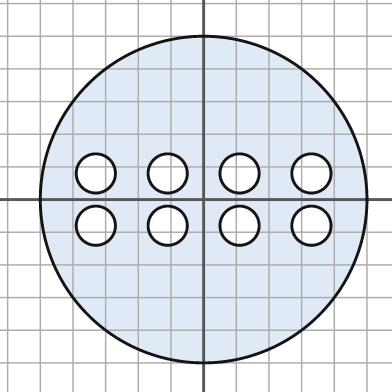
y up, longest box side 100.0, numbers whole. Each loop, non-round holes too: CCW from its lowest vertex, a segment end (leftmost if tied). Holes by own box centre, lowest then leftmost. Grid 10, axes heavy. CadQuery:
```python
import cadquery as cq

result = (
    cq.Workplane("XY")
    .moveTo(0.0, 0.0)
    .circle(50.0)
    .moveTo(-33.0, -8.0)
    .circle(6.0)
    .moveTo(-11.0, -8.0)
    .circle(6.0)
    .moveTo(11.0, -8.0)
    .circle(6.0)
    .moveTo(33.0, -8.0)
    .circle(6.0)
    .moveTo(-33.0, 8.0)
    .circle(6.0)
    .moveTo(-11.0, 8.0)
    .circle(6.0)
    .moveTo(11.0, 8.0)
    .circle(6.0)
    .moveTo(33.0, 8.0)
    .circle(6.0)
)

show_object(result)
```